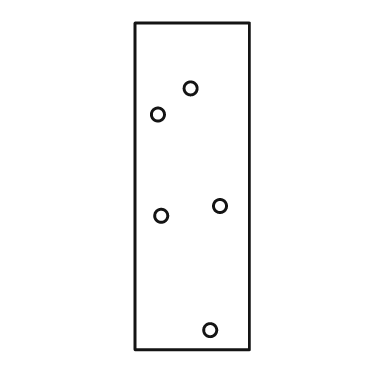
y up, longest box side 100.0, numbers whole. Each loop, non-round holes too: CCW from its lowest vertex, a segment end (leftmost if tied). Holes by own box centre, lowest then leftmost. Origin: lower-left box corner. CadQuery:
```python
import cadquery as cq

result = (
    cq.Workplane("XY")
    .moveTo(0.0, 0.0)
    .lineTo(35.0, 0.0)
    .lineTo(35.0, 100.0)
    .lineTo(0.0, 100.0)
    .close()
    .moveTo(23.0, 6.0)
    .circle(2.0)
    .moveTo(8.0, 41.0)
    .circle(2.0)
    .moveTo(26.0, 44.0)
    .circle(2.0)
    .moveTo(7.0, 72.0)
    .circle(2.0)
    .moveTo(17.0, 80.0)
    .circle(2.0)
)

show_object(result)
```